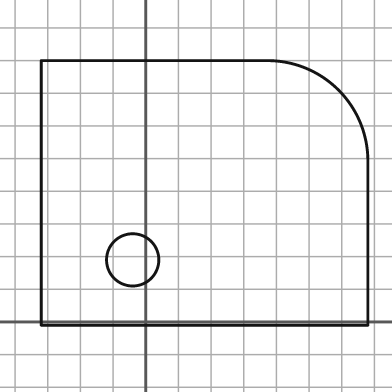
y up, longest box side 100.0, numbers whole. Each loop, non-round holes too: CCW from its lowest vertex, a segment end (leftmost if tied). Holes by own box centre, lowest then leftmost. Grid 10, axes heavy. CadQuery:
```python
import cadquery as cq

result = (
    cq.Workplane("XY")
    .moveTo(-32.0, -1.0)
    .lineTo(68.0, -1.0)
    .lineTo(68.0, 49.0)
    .threePointArc((59.0, 71.0), (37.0, 80.0))
    .lineTo(-32.0, 80.0)
    .close()
    .moveTo(-4.0, 19.0)
    .circle(8.0)
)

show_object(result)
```